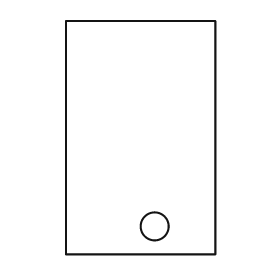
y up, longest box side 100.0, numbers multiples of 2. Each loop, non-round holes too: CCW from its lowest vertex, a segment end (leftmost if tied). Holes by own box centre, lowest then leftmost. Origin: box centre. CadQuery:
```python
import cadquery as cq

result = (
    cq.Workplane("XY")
    .moveTo(-32.0, -50.0)
    .lineTo(32.0, -50.0)
    .lineTo(32.0, 50.0)
    .lineTo(-32.0, 50.0)
    .close()
    .moveTo(6.0, -38.0)
    .circle(6.0)
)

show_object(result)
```